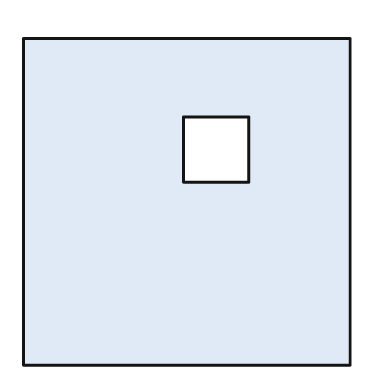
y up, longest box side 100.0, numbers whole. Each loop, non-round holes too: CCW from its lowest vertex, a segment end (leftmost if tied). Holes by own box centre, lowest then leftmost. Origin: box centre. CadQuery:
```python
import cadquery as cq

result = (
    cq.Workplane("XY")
    .moveTo(-50.0, -50.0)
    .lineTo(50.0, -50.0)
    .lineTo(50.0, 50.0)
    .lineTo(-50.0, 50.0)
    .close()
    .moveTo(-1.0, 6.0)
    .lineTo(19.0, 6.0)
    .lineTo(19.0, 26.0)
    .lineTo(-1.0, 26.0)
    .close()
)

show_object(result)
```